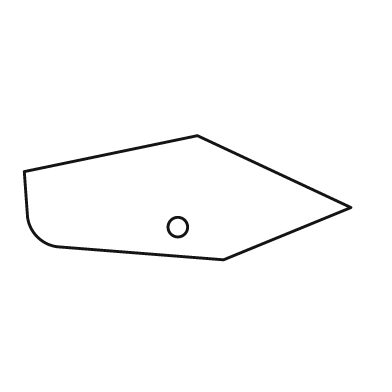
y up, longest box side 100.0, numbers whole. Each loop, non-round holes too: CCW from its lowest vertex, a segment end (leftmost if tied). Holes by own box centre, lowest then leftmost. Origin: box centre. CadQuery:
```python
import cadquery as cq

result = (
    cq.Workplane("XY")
    .moveTo(11.0, -19.0)
    .lineTo(50.0, -3.0)
    .lineTo(3.0, 19.0)
    .lineTo(-50.0, 8.0)
    .lineTo(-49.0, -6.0)
    .threePointArc((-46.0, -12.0), (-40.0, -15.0))
    .close()
    .moveTo(-3.0, -9.0)
    .circle(3.0)
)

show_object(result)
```